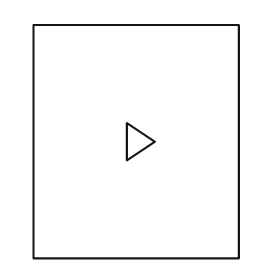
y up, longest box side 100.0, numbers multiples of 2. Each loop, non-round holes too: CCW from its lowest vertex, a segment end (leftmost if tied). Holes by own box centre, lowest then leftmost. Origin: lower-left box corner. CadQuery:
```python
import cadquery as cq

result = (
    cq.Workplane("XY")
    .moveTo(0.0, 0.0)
    .lineTo(88.0, 0.0)
    .lineTo(88.0, 100.0)
    .lineTo(0.0, 100.0)
    .close()
    .moveTo(40.0, 42.0)
    .lineTo(52.0, 50.0)
    .lineTo(40.0, 58.0)
    .close()
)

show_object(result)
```